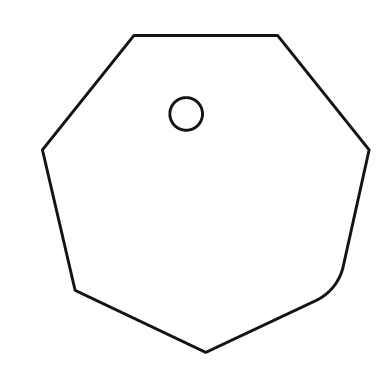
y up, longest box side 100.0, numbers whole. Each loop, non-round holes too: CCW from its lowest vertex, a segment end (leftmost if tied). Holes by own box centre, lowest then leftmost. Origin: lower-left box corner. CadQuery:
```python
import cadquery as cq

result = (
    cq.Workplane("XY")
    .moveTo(50.0, 0.0)
    .lineTo(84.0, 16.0)
    .threePointArc((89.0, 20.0), (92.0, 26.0))
    .lineTo(100.0, 62.0)
    .lineTo(72.0, 97.0)
    .lineTo(28.0, 97.0)
    .lineTo(0.0, 62.0)
    .lineTo(10.0, 19.0)
    .close()
    .moveTo(44.0, 73.0)
    .circle(5.0)
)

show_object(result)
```